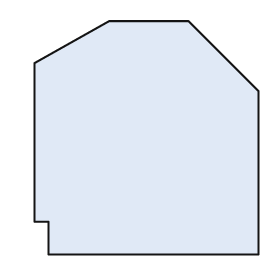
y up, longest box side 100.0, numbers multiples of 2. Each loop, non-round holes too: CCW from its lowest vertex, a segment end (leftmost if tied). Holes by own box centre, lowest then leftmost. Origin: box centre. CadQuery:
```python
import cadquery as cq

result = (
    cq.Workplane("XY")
    .moveTo(-42.0, -50.0)
    .lineTo(48.0, -50.0)
    .lineTo(48.0, 20.0)
    .lineTo(18.0, 50.0)
    .lineTo(-16.0, 50.0)
    .lineTo(-48.0, 32.0)
    .lineTo(-48.0, -36.0)
    .lineTo(-42.0, -36.0)
    .close()
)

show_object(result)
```